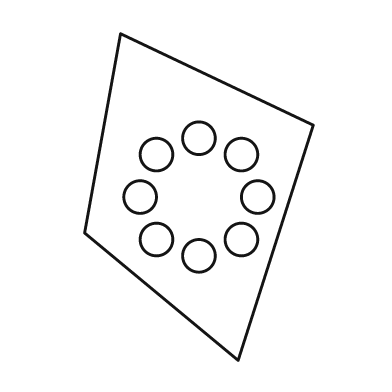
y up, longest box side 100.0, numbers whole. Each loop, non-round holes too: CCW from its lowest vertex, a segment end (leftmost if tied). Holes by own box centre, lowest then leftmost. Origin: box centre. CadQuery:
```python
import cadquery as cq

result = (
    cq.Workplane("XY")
    .moveTo(12.0, -50.0)
    .lineTo(35.0, 22.0)
    .lineTo(-24.0, 50.0)
    .lineTo(-35.0, -11.0)
    .close()
    .moveTo(0.0, -18.0)
    .circle(5.0)
    .moveTo(-13.0, -13.0)
    .circle(5.0)
    .moveTo(13.0, -13.0)
    .circle(5.0)
    .moveTo(-18.0, 0.0)
    .circle(5.0)
    .moveTo(18.0, 0.0)
    .circle(5.0)
    .moveTo(-13.0, 13.0)
    .circle(5.0)
    .moveTo(13.0, 13.0)
    .circle(5.0)
    .moveTo(0.0, 18.0)
    .circle(5.0)
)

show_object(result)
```